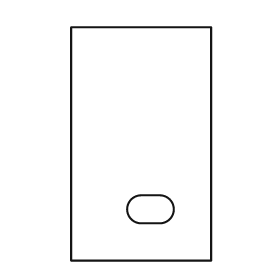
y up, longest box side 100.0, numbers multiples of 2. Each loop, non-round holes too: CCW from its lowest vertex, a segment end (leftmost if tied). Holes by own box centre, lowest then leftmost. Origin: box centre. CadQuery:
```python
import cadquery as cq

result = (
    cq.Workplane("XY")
    .moveTo(-30.0, -50.0)
    .lineTo(30.0, -50.0)
    .lineTo(30.0, 50.0)
    .lineTo(-30.0, 50.0)
    .close()
    .moveTo(0.0, -34.0)
    .lineTo(8.0, -34.0)
    .threePointArc((14.0, -28.0), (8.0, -22.0))
    .lineTo(0.0, -22.0)
    .threePointArc((-6.0, -28.0), (0.0, -34.0))
    .close()
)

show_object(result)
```